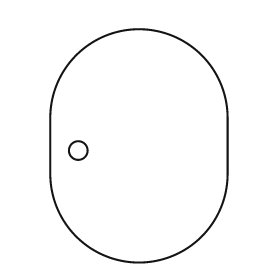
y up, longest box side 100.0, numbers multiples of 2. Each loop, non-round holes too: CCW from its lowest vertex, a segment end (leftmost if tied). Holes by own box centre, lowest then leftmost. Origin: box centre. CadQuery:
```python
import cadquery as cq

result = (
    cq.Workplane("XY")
    .moveTo(-38.0, -12.0)
    .threePointArc((0.0, -50.0), (38.0, -12.0))
    .lineTo(38.0, 12.0)
    .threePointArc((0.0, 50.0), (-38.0, 12.0))
    .close()
    .moveTo(-26.0, -2.0)
    .circle(4.0)
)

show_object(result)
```